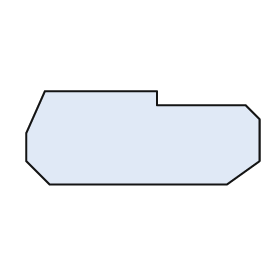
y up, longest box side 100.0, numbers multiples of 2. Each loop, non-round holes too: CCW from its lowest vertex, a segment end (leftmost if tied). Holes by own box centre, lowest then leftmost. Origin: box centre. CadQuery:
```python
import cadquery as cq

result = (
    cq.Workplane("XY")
    .moveTo(-40.0, -20.0)
    .lineTo(36.0, -20.0)
    .lineTo(50.0, -10.0)
    .lineTo(50.0, 8.0)
    .lineTo(44.0, 14.0)
    .lineTo(6.0, 14.0)
    .lineTo(6.0, 20.0)
    .lineTo(-42.0, 20.0)
    .lineTo(-50.0, 2.0)
    .lineTo(-50.0, -10.0)
    .close()
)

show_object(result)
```